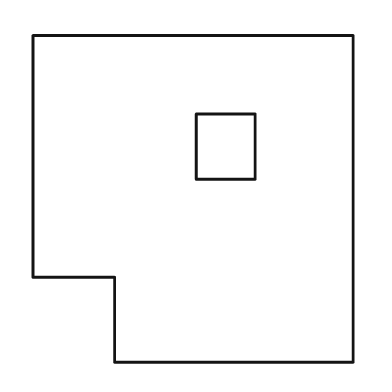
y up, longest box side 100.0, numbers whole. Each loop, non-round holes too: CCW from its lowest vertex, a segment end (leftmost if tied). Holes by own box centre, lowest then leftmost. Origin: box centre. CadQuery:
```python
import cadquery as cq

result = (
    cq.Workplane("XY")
    .moveTo(-24.0, -50.0)
    .lineTo(49.0, -50.0)
    .lineTo(49.0, 50.0)
    .lineTo(-49.0, 50.0)
    .lineTo(-49.0, -24.0)
    .lineTo(-24.0, -24.0)
    .close()
    .moveTo(1.0, 6.0)
    .lineTo(19.0, 6.0)
    .lineTo(19.0, 26.0)
    .lineTo(1.0, 26.0)
    .close()
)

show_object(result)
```